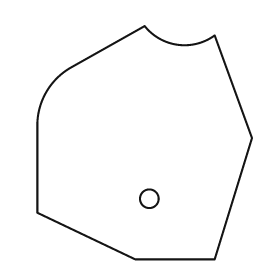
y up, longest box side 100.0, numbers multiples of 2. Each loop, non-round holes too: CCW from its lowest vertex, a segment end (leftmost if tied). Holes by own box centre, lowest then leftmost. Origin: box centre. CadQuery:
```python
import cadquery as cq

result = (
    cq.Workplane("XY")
    .moveTo(-4.0, -50.0)
    .lineTo(30.0, -50.0)
    .lineTo(46.0, 2.0)
    .lineTo(30.0, 46.0)
    .threePointArc((14.0, 42.0), (0.0, 50.0))
    .lineTo(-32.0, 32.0)
    .threePointArc((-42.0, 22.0), (-46.0, 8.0))
    .lineTo(-46.0, -30.0)
    .close()
    .moveTo(2.0, -24.0)
    .circle(4.0)
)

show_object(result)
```